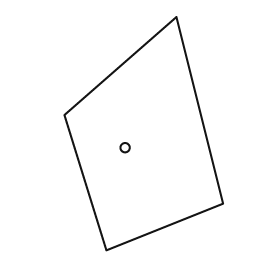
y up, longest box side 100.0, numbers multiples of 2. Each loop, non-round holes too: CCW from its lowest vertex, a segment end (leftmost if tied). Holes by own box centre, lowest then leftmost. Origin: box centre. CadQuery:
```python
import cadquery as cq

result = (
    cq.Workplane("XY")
    .moveTo(-16.0, -50.0)
    .lineTo(34.0, -30.0)
    .lineTo(14.0, 50.0)
    .lineTo(-34.0, 8.0)
    .close()
    .moveTo(-8.0, -6.0)
    .circle(2.0)
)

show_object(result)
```